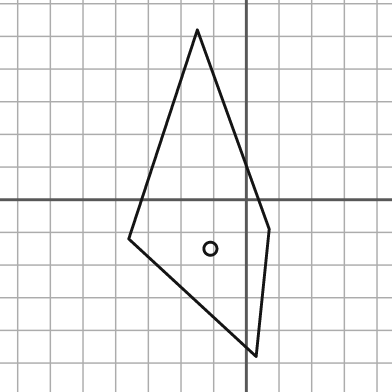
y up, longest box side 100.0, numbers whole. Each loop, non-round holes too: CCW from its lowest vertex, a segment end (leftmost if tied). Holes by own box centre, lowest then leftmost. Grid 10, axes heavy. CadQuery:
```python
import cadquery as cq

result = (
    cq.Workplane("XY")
    .moveTo(3.0, -48.0)
    .lineTo(7.0, -9.0)
    .lineTo(-15.0, 52.0)
    .lineTo(-36.0, -12.0)
    .close()
    .moveTo(-11.0, -15.0)
    .circle(2.0)
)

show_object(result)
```